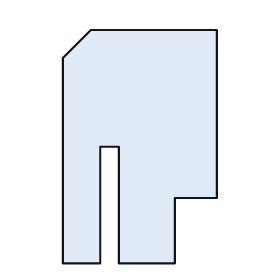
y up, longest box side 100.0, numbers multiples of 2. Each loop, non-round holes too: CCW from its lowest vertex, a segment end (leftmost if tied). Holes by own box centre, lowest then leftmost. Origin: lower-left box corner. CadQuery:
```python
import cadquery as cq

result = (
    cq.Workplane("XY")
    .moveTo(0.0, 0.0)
    .lineTo(16.0, 0.0)
    .lineTo(16.0, 50.0)
    .lineTo(24.0, 50.0)
    .lineTo(24.0, 0.0)
    .lineTo(48.0, 0.0)
    .lineTo(48.0, 28.0)
    .lineTo(66.0, 28.0)
    .lineTo(66.0, 100.0)
    .lineTo(12.0, 100.0)
    .lineTo(0.0, 88.0)
    .close()
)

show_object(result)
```